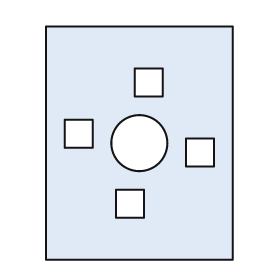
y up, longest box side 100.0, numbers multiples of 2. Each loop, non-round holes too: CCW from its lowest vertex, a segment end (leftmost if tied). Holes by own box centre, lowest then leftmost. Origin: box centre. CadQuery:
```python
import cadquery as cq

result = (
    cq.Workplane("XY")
    .moveTo(-40.0, -50.0)
    .lineTo(40.0, -50.0)
    .lineTo(40.0, 50.0)
    .lineTo(-40.0, 50.0)
    .close()
    .moveTo(-10.0, -32.0)
    .lineTo(2.0, -32.0)
    .lineTo(2.0, -20.0)
    .lineTo(-10.0, -20.0)
    .close()
    .moveTo(20.0, -10.0)
    .lineTo(32.0, -10.0)
    .lineTo(32.0, 2.0)
    .lineTo(20.0, 2.0)
    .close()
    .moveTo(0.0, 0.0)
    .circle(12.0)
    .moveTo(-32.0, -2.0)
    .lineTo(-20.0, -2.0)
    .lineTo(-20.0, 10.0)
    .lineTo(-32.0, 10.0)
    .close()
    .moveTo(-2.0, 20.0)
    .lineTo(10.0, 20.0)
    .lineTo(10.0, 32.0)
    .lineTo(-2.0, 32.0)
    .close()
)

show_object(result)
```